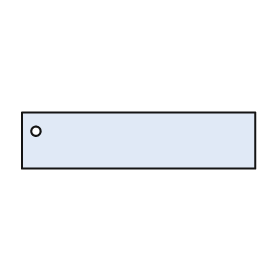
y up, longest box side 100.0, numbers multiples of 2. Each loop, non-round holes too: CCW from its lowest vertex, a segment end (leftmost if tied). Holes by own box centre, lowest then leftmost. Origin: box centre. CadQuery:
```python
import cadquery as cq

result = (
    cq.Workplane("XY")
    .moveTo(-50.0, -12.0)
    .lineTo(50.0, -12.0)
    .lineTo(50.0, 12.0)
    .lineTo(-50.0, 12.0)
    .close()
    .moveTo(-44.0, 4.0)
    .circle(2.0)
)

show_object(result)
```